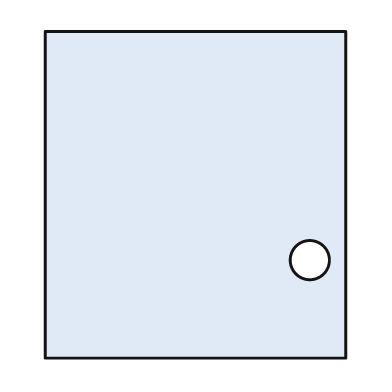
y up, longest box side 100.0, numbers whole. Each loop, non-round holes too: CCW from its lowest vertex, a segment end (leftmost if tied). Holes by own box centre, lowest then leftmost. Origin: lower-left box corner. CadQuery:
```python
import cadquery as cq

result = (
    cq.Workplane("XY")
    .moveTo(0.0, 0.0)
    .lineTo(92.0, 0.0)
    .lineTo(92.0, 100.0)
    .lineTo(0.0, 100.0)
    .close()
    .moveTo(81.0, 30.0)
    .circle(6.0)
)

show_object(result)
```